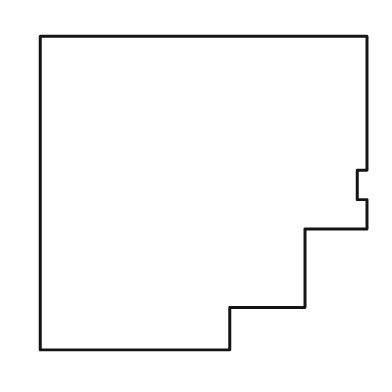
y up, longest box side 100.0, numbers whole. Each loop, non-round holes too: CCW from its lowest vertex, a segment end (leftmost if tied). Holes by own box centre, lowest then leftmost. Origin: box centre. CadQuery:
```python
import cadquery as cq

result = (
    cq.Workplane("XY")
    .moveTo(-50.0, -48.0)
    .lineTo(8.0, -48.0)
    .lineTo(8.0, -35.0)
    .lineTo(31.0, -35.0)
    .lineTo(31.0, -11.0)
    .lineTo(50.0, -11.0)
    .lineTo(50.0, -2.0)
    .lineTo(47.0, -2.0)
    .lineTo(47.0, 7.0)
    .lineTo(50.0, 7.0)
    .lineTo(50.0, 48.0)
    .lineTo(-50.0, 48.0)
    .close()
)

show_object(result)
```